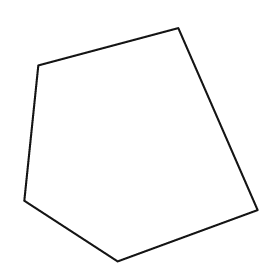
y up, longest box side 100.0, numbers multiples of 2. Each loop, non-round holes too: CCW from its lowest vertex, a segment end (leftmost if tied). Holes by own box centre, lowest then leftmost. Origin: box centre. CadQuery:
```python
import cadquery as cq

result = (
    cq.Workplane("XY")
    .moveTo(-10.0, -50.0)
    .lineTo(50.0, -28.0)
    .lineTo(16.0, 50.0)
    .lineTo(-44.0, 34.0)
    .lineTo(-50.0, -24.0)
    .close()
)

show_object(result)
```